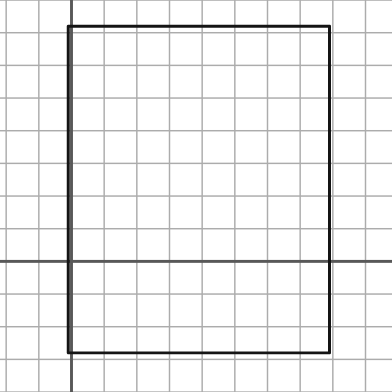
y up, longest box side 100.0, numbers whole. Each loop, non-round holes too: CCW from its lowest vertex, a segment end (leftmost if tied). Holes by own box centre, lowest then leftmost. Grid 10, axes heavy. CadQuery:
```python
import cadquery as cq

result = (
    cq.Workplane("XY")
    .moveTo(-1.0, -28.0)
    .lineTo(79.0, -28.0)
    .lineTo(79.0, 72.0)
    .lineTo(-1.0, 72.0)
    .close()
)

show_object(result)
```